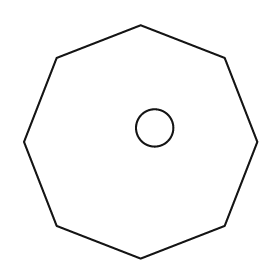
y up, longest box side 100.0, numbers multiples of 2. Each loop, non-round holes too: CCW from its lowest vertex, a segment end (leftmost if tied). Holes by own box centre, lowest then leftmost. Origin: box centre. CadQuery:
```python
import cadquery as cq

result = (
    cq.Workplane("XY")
    .moveTo(0.0, -50.0)
    .lineTo(36.0, -36.0)
    .lineTo(50.0, 0.0)
    .lineTo(36.0, 36.0)
    .lineTo(0.0, 50.0)
    .lineTo(-36.0, 36.0)
    .lineTo(-50.0, 0.0)
    .lineTo(-36.0, -36.0)
    .close()
    .moveTo(6.0, 6.0)
    .circle(8.0)
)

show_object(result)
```